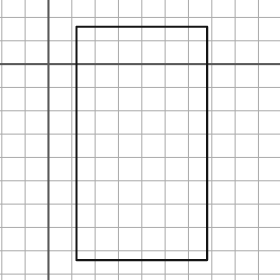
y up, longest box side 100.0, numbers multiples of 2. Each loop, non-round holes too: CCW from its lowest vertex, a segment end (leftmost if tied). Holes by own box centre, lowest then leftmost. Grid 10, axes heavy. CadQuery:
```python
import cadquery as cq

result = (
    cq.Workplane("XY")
    .moveTo(12.0, -84.0)
    .lineTo(68.0, -84.0)
    .lineTo(68.0, 16.0)
    .lineTo(12.0, 16.0)
    .close()
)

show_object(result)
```